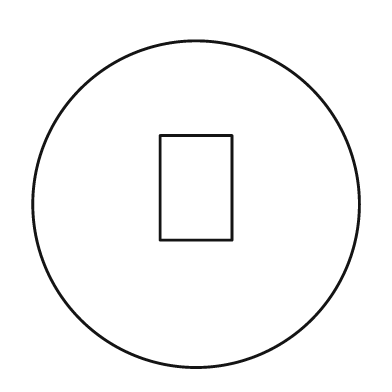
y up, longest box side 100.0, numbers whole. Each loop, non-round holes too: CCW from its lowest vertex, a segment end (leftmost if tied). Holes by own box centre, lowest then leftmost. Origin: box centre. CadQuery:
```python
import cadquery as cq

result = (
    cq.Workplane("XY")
    .moveTo(0.0, 0.0)
    .circle(50.0)
    .moveTo(-11.0, -11.0)
    .lineTo(11.0, -11.0)
    .lineTo(11.0, 21.0)
    .lineTo(-11.0, 21.0)
    .close()
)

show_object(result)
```